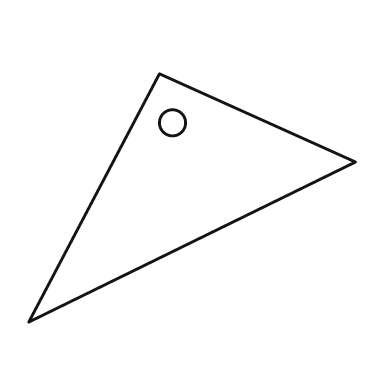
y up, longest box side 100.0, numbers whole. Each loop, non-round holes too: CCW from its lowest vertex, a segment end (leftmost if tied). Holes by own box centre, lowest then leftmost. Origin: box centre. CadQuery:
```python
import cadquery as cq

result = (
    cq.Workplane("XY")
    .moveTo(-50.0, -38.0)
    .lineTo(50.0, 11.0)
    .lineTo(-10.0, 38.0)
    .close()
    .moveTo(-6.0, 23.0)
    .circle(4.0)
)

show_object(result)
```